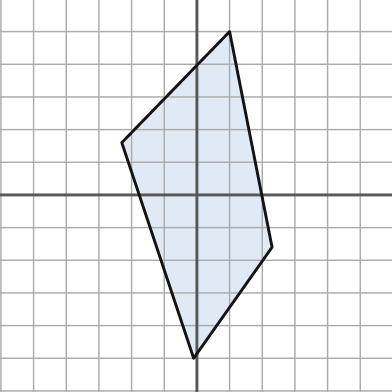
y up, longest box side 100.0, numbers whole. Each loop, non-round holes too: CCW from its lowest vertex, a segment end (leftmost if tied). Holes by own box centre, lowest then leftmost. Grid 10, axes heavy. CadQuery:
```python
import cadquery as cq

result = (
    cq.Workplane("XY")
    .moveTo(-1.0, -50.0)
    .lineTo(23.0, -16.0)
    .lineTo(10.0, 50.0)
    .lineTo(-23.0, 16.0)
    .close()
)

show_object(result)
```